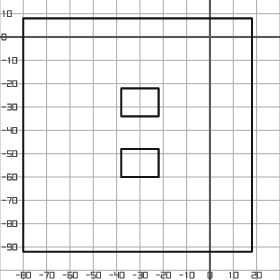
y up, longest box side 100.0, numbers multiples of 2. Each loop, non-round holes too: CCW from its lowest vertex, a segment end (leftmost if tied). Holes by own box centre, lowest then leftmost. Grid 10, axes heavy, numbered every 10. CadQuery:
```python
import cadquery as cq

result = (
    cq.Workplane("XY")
    .moveTo(-80.0, -92.0)
    .lineTo(18.0, -92.0)
    .lineTo(18.0, 8.0)
    .lineTo(-80.0, 8.0)
    .close()
    .moveTo(-38.0, -60.0)
    .lineTo(-22.0, -60.0)
    .lineTo(-22.0, -48.0)
    .lineTo(-38.0, -48.0)
    .close()
    .moveTo(-38.0, -34.0)
    .lineTo(-22.0, -34.0)
    .lineTo(-22.0, -22.0)
    .lineTo(-38.0, -22.0)
    .close()
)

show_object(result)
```